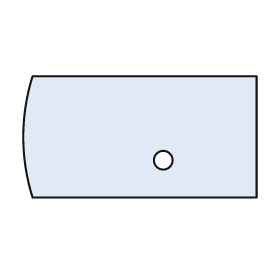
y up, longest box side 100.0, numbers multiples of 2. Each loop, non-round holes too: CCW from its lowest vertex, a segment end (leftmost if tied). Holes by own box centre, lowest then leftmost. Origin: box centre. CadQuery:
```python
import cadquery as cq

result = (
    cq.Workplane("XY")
    .moveTo(-46.0, -26.0)
    .lineTo(50.0, -26.0)
    .lineTo(50.0, 26.0)
    .lineTo(-46.0, 26.0)
    .threePointArc((-50.0, 0.0), (-46.0, -26.0))
    .close()
    .moveTo(10.0, -10.0)
    .circle(4.0)
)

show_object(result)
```